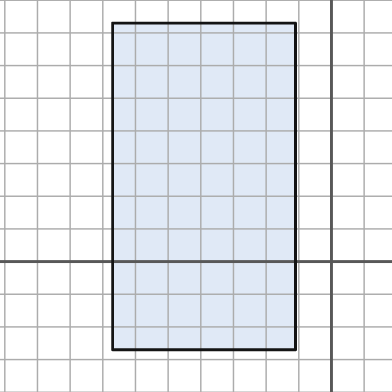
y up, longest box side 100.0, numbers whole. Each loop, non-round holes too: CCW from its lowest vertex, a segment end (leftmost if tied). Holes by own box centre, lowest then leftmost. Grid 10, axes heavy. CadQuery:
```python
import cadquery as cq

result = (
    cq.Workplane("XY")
    .moveTo(-67.0, -27.0)
    .lineTo(-11.0, -27.0)
    .lineTo(-11.0, 73.0)
    .lineTo(-67.0, 73.0)
    .close()
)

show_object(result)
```